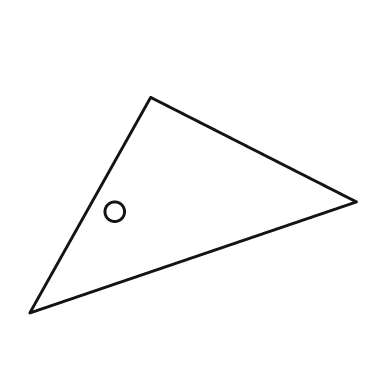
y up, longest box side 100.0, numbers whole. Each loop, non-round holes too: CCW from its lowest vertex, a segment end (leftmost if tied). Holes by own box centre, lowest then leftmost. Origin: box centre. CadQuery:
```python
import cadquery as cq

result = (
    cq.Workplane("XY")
    .moveTo(-50.0, -33.0)
    .lineTo(50.0, 1.0)
    .lineTo(-13.0, 33.0)
    .close()
    .moveTo(-24.0, -2.0)
    .circle(3.0)
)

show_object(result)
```